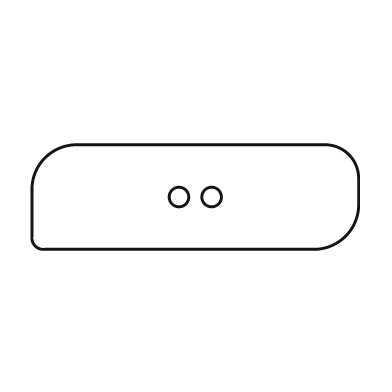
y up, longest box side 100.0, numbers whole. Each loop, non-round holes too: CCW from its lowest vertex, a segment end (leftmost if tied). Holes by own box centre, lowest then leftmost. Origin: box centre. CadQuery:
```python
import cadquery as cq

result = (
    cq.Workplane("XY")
    .moveTo(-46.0, -16.0)
    .lineTo(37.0, -16.0)
    .threePointArc((46.0, -12.0), (50.0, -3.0))
    .lineTo(50.0, 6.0)
    .threePointArc((47.0, 13.0), (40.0, 16.0))
    .lineTo(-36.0, 16.0)
    .threePointArc((-46.0, 12.0), (-50.0, 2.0))
    .lineTo(-50.0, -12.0)
    .threePointArc((-49.0, -15.0), (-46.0, -16.0))
    .close()
    .moveTo(-5.0, 0.0)
    .circle(3.0)
    .moveTo(5.0, 0.0)
    .circle(3.0)
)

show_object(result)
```